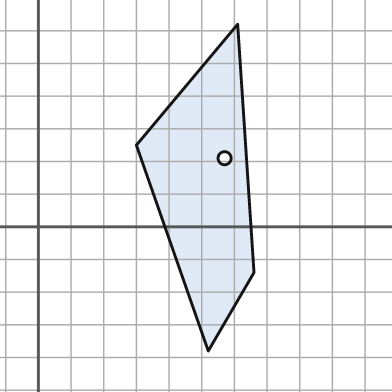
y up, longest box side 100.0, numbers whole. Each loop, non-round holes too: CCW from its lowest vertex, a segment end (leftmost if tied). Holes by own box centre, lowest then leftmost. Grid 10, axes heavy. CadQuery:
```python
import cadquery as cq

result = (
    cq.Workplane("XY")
    .moveTo(52.0, -38.0)
    .lineTo(66.0, -14.0)
    .lineTo(61.0, 62.0)
    .lineTo(30.0, 25.0)
    .close()
    .moveTo(57.0, 21.0)
    .circle(2.0)
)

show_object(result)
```